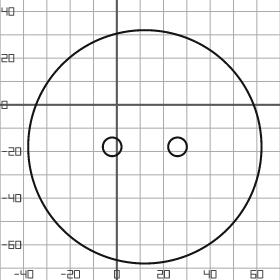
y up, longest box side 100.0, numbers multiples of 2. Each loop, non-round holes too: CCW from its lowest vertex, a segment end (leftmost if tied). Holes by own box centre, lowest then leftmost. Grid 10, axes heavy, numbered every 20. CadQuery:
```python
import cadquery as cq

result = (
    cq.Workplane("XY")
    .moveTo(12.0, -18.0)
    .circle(50.0)
    .moveTo(-2.0, -18.0)
    .circle(4.0)
    .moveTo(26.0, -18.0)
    .circle(4.0)
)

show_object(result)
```